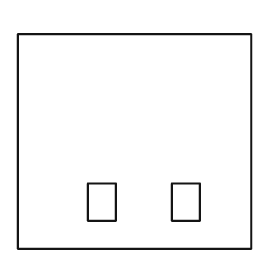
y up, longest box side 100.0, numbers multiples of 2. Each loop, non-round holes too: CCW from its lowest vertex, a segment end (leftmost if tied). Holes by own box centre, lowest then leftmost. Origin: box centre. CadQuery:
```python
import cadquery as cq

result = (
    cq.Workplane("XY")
    .moveTo(-50.0, -46.0)
    .lineTo(50.0, -46.0)
    .lineTo(50.0, 46.0)
    .lineTo(-50.0, 46.0)
    .close()
    .moveTo(-20.0, -34.0)
    .lineTo(-8.0, -34.0)
    .lineTo(-8.0, -18.0)
    .lineTo(-20.0, -18.0)
    .close()
    .moveTo(16.0, -34.0)
    .lineTo(28.0, -34.0)
    .lineTo(28.0, -18.0)
    .lineTo(16.0, -18.0)
    .close()
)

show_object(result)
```